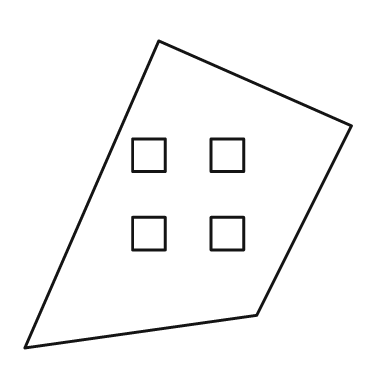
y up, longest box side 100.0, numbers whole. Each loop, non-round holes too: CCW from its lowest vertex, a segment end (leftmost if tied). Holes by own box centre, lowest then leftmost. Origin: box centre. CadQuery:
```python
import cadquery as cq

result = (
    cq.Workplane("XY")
    .moveTo(-50.0, -47.0)
    .lineTo(21.0, -37.0)
    .lineTo(50.0, 21.0)
    .lineTo(-9.0, 47.0)
    .close()
    .moveTo(-17.0, -17.0)
    .lineTo(-7.0, -17.0)
    .lineTo(-7.0, -7.0)
    .lineTo(-17.0, -7.0)
    .close()
    .moveTo(7.0, -17.0)
    .lineTo(17.0, -17.0)
    .lineTo(17.0, -7.0)
    .lineTo(7.0, -7.0)
    .close()
    .moveTo(-17.0, 7.0)
    .lineTo(-7.0, 7.0)
    .lineTo(-7.0, 17.0)
    .lineTo(-17.0, 17.0)
    .close()
    .moveTo(7.0, 7.0)
    .lineTo(17.0, 7.0)
    .lineTo(17.0, 17.0)
    .lineTo(7.0, 17.0)
    .close()
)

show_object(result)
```